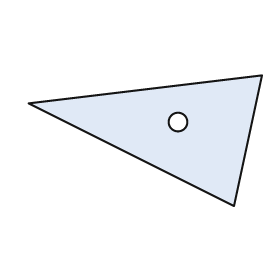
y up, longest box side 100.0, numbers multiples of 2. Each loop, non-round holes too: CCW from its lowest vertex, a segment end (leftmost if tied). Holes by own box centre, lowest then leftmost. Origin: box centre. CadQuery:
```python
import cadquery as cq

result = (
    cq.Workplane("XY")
    .moveTo(38.0, -28.0)
    .lineTo(50.0, 28.0)
    .lineTo(-50.0, 16.0)
    .close()
    .moveTo(14.0, 8.0)
    .circle(4.0)
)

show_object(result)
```